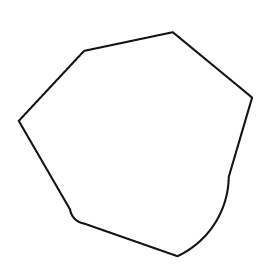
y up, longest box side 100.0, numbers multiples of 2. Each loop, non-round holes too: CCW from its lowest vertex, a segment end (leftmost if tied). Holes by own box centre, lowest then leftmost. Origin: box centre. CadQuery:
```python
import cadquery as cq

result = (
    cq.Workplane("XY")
    .moveTo(18.0, -48.0)
    .threePointArc((34.0, -34.0), (40.0, -14.0))
    .lineTo(50.0, 20.0)
    .lineTo(16.0, 48.0)
    .lineTo(-22.0, 40.0)
    .lineTo(-50.0, 10.0)
    .lineTo(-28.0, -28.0)
    .threePointArc((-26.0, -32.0), (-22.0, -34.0))
    .close()
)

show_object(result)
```